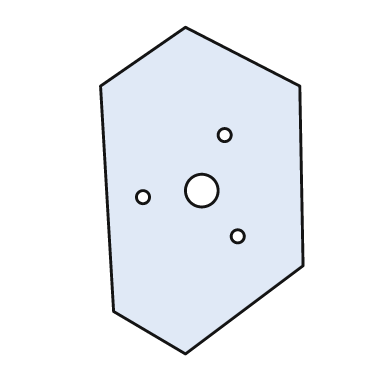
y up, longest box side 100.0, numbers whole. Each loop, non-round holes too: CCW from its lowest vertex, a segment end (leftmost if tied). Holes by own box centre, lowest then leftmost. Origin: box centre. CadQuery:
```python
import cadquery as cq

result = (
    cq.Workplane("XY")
    .moveTo(-5.0, -50.0)
    .lineTo(31.0, -23.0)
    .lineTo(30.0, 32.0)
    .lineTo(-5.0, 50.0)
    .lineTo(-31.0, 32.0)
    .lineTo(-27.0, -37.0)
    .close()
    .moveTo(11.0, -14.0)
    .circle(2.0)
    .moveTo(-18.0, -2.0)
    .circle(2.0)
    .moveTo(0.0, 0.0)
    .circle(5.0)
    .moveTo(7.0, 17.0)
    .circle(2.0)
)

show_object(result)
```